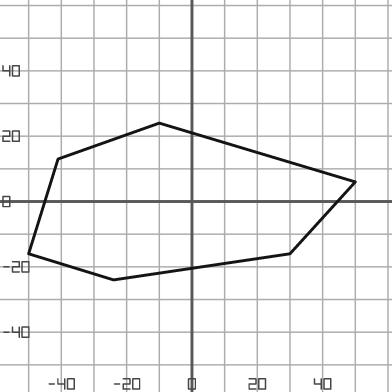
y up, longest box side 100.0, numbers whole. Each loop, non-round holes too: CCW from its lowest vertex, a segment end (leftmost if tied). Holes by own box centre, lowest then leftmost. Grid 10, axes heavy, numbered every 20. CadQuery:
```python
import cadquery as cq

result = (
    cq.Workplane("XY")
    .moveTo(-24.0, -24.0)
    .lineTo(30.0, -16.0)
    .lineTo(50.0, 6.0)
    .lineTo(-10.0, 24.0)
    .lineTo(-41.0, 13.0)
    .lineTo(-50.0, -16.0)
    .close()
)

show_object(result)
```